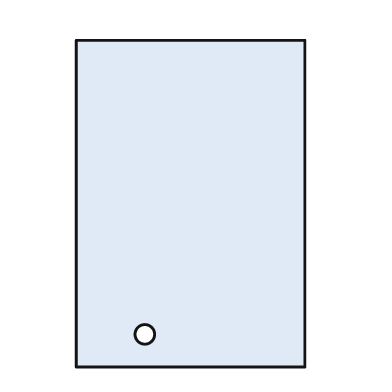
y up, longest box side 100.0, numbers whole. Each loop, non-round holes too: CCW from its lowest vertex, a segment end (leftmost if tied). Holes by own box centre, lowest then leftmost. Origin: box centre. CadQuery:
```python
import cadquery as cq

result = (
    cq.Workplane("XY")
    .moveTo(-35.0, -50.0)
    .lineTo(35.0, -50.0)
    .lineTo(35.0, 50.0)
    .lineTo(-35.0, 50.0)
    .close()
    .moveTo(-14.0, -40.0)
    .circle(3.0)
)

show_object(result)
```